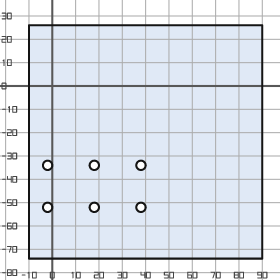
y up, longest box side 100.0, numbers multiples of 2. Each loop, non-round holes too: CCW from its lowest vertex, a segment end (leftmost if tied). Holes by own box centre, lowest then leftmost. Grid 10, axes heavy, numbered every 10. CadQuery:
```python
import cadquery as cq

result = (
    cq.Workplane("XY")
    .moveTo(-10.0, -74.0)
    .lineTo(90.0, -74.0)
    .lineTo(90.0, 26.0)
    .lineTo(-10.0, 26.0)
    .close()
    .moveTo(-2.0, -52.0)
    .circle(2.0)
    .moveTo(18.0, -52.0)
    .circle(2.0)
    .moveTo(38.0, -52.0)
    .circle(2.0)
    .moveTo(-2.0, -34.0)
    .circle(2.0)
    .moveTo(18.0, -34.0)
    .circle(2.0)
    .moveTo(38.0, -34.0)
    .circle(2.0)
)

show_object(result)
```